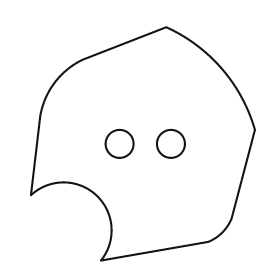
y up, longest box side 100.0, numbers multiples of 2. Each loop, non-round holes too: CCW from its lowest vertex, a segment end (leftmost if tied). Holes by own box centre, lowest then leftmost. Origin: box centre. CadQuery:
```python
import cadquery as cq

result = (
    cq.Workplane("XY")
    .moveTo(-18.0, -50.0)
    .lineTo(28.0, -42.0)
    .threePointArc((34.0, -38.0), (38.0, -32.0))
    .lineTo(48.0, 6.0)
    .threePointArc((34.0, 32.0), (10.0, 50.0))
    .lineTo(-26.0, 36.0)
    .threePointArc((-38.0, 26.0), (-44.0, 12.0))
    .lineTo(-48.0, -22.0)
    .threePointArc((-20.0, -22.0), (-18.0, -50.0))
    .close()
    .moveTo(-10.0, 0.0)
    .circle(6.0)
    .moveTo(12.0, 0.0)
    .circle(6.0)
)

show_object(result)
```